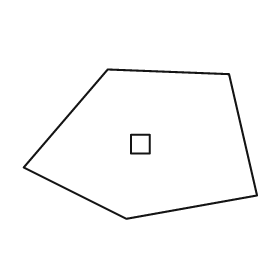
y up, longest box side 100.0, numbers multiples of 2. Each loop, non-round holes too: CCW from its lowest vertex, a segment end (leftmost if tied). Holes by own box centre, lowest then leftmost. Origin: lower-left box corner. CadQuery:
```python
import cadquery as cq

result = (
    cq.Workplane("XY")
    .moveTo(44.0, 0.0)
    .lineTo(100.0, 10.0)
    .lineTo(88.0, 62.0)
    .lineTo(36.0, 64.0)
    .lineTo(0.0, 22.0)
    .close()
    .moveTo(46.0, 28.0)
    .lineTo(54.0, 28.0)
    .lineTo(54.0, 36.0)
    .lineTo(46.0, 36.0)
    .close()
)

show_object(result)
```